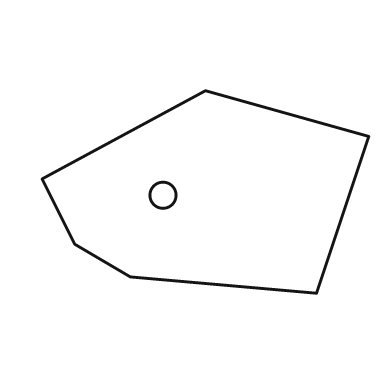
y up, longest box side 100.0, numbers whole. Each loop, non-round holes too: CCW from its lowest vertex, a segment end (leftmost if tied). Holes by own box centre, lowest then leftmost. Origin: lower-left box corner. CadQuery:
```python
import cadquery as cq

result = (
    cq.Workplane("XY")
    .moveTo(84.0, 0.0)
    .lineTo(100.0, 48.0)
    .lineTo(50.0, 62.0)
    .lineTo(0.0, 35.0)
    .lineTo(10.0, 15.0)
    .lineTo(27.0, 5.0)
    .close()
    .moveTo(37.0, 30.0)
    .circle(4.0)
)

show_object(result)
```